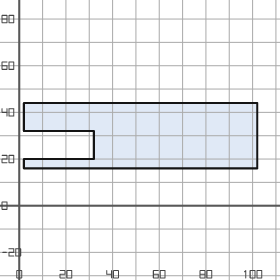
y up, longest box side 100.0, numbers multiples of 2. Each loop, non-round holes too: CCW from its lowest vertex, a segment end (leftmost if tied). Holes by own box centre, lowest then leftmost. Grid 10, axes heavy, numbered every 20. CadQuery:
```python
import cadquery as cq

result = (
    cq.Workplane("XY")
    .moveTo(2.0, 16.0)
    .lineTo(102.0, 16.0)
    .lineTo(102.0, 44.0)
    .lineTo(2.0, 44.0)
    .lineTo(2.0, 32.0)
    .lineTo(32.0, 32.0)
    .lineTo(32.0, 20.0)
    .lineTo(2.0, 20.0)
    .close()
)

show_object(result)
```